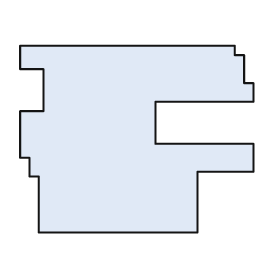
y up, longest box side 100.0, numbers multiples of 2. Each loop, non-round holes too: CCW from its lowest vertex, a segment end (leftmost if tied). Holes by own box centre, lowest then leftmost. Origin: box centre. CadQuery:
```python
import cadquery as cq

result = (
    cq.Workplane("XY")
    .moveTo(-42.0, -40.0)
    .lineTo(26.0, -40.0)
    .lineTo(26.0, -14.0)
    .lineTo(50.0, -14.0)
    .lineTo(50.0, -2.0)
    .lineTo(8.0, -2.0)
    .lineTo(8.0, 16.0)
    .lineTo(50.0, 16.0)
    .lineTo(50.0, 24.0)
    .lineTo(46.0, 24.0)
    .lineTo(46.0, 36.0)
    .lineTo(42.0, 36.0)
    .lineTo(42.0, 40.0)
    .lineTo(-50.0, 40.0)
    .lineTo(-50.0, 30.0)
    .lineTo(-40.0, 30.0)
    .lineTo(-40.0, 12.0)
    .lineTo(-50.0, 12.0)
    .lineTo(-50.0, -8.0)
    .lineTo(-46.0, -8.0)
    .lineTo(-46.0, -16.0)
    .lineTo(-42.0, -16.0)
    .close()
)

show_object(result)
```